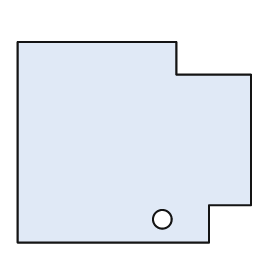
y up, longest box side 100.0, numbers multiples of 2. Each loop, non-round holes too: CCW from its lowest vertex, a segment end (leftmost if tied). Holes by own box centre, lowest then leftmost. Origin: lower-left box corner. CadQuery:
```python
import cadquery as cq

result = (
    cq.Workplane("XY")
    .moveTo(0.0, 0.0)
    .lineTo(82.0, 0.0)
    .lineTo(82.0, 16.0)
    .lineTo(100.0, 16.0)
    .lineTo(100.0, 72.0)
    .lineTo(68.0, 72.0)
    .lineTo(68.0, 86.0)
    .lineTo(0.0, 86.0)
    .close()
    .moveTo(62.0, 10.0)
    .circle(4.0)
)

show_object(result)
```